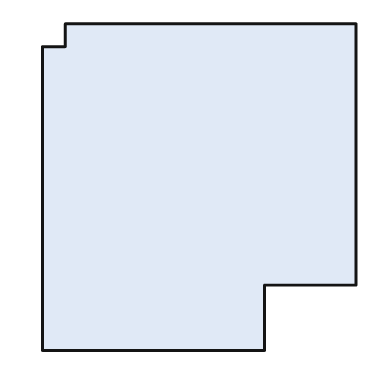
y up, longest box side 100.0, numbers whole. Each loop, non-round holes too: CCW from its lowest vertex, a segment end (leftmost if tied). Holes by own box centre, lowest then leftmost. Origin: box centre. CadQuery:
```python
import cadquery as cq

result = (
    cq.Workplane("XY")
    .moveTo(-48.0, -50.0)
    .lineTo(20.0, -50.0)
    .lineTo(20.0, -30.0)
    .lineTo(48.0, -30.0)
    .lineTo(48.0, 50.0)
    .lineTo(-41.0, 50.0)
    .lineTo(-41.0, 43.0)
    .lineTo(-48.0, 43.0)
    .close()
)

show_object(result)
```